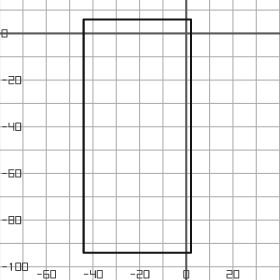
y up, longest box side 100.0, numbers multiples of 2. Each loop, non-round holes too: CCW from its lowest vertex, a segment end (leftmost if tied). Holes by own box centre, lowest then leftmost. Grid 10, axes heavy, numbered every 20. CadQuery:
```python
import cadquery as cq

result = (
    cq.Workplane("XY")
    .moveTo(-44.0, -94.0)
    .lineTo(2.0, -94.0)
    .lineTo(2.0, 6.0)
    .lineTo(-44.0, 6.0)
    .close()
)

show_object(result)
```